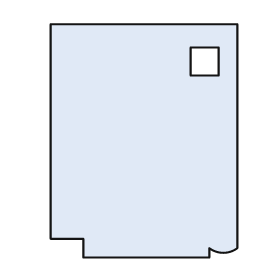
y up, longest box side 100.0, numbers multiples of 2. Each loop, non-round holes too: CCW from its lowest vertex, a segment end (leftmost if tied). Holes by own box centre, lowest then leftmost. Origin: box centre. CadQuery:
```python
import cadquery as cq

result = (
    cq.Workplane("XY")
    .moveTo(-26.0, -50.0)
    .lineTo(28.0, -50.0)
    .lineTo(28.0, -46.0)
    .threePointArc((34.0, -48.0), (40.0, -46.0))
    .lineTo(40.0, 50.0)
    .lineTo(-40.0, 50.0)
    .lineTo(-40.0, -42.0)
    .lineTo(-26.0, -42.0)
    .close()
    .moveTo(20.0, 28.0)
    .lineTo(32.0, 28.0)
    .lineTo(32.0, 40.0)
    .lineTo(20.0, 40.0)
    .close()
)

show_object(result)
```